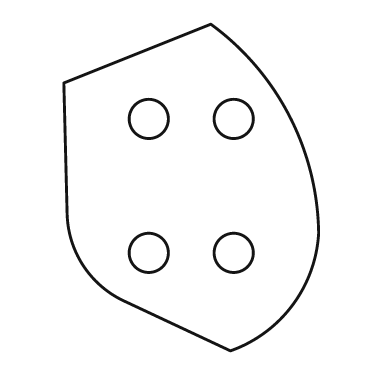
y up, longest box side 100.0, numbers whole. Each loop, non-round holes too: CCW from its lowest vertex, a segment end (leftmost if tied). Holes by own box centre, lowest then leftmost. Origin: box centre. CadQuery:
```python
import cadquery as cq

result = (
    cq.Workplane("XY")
    .moveTo(12.0, -50.0)
    .threePointArc((31.0, -36.0), (39.0, -14.0))
    .threePointArc((30.0, 22.0), (6.0, 50.0))
    .lineTo(-39.0, 32.0)
    .lineTo(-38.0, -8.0)
    .threePointArc((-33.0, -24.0), (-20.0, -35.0))
    .close()
    .moveTo(-13.0, -20.0)
    .circle(6.0)
    .moveTo(13.0, -20.0)
    .circle(6.0)
    .moveTo(-13.0, 21.0)
    .circle(6.0)
    .moveTo(13.0, 21.0)
    .circle(6.0)
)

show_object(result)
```